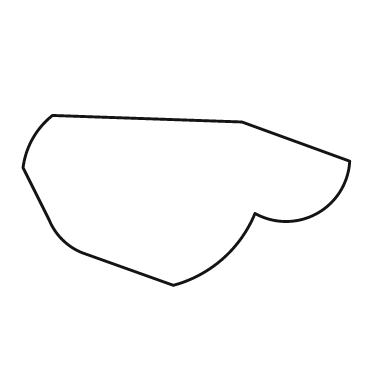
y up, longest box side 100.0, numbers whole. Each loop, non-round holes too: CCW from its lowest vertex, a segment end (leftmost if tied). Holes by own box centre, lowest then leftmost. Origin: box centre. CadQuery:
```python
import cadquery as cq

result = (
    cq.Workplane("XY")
    .moveTo(-4.0, -26.0)
    .threePointArc((11.0, -18.0), (21.0, -4.0))
    .threePointArc((40.0, -4.0), (50.0, 12.0))
    .lineTo(17.0, 24.0)
    .lineTo(-41.0, 26.0)
    .threePointArc((-47.0, 19.0), (-50.0, 10.0))
    .lineTo(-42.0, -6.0)
    .threePointArc((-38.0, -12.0), (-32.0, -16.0))
    .close()
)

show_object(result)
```